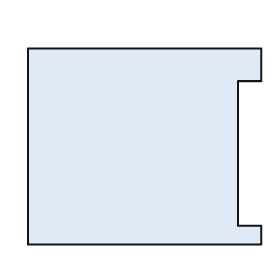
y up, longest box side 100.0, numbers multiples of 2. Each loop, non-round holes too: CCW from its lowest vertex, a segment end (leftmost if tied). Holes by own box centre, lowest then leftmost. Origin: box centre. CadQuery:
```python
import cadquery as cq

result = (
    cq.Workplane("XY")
    .moveTo(-50.0, -42.0)
    .lineTo(50.0, -42.0)
    .lineTo(50.0, -34.0)
    .lineTo(40.0, -34.0)
    .lineTo(40.0, 28.0)
    .lineTo(50.0, 28.0)
    .lineTo(50.0, 42.0)
    .lineTo(-50.0, 42.0)
    .close()
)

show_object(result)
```